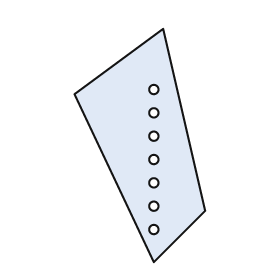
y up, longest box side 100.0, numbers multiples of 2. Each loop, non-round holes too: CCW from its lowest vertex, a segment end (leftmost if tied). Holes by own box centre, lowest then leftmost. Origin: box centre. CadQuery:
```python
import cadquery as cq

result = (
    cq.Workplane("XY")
    .moveTo(6.0, -50.0)
    .lineTo(28.0, -28.0)
    .lineTo(10.0, 50.0)
    .lineTo(-28.0, 22.0)
    .close()
    .moveTo(6.0, -36.0)
    .circle(2.0)
    .moveTo(6.0, -26.0)
    .circle(2.0)
    .moveTo(6.0, -16.0)
    .circle(2.0)
    .moveTo(6.0, -6.0)
    .circle(2.0)
    .moveTo(6.0, 4.0)
    .circle(2.0)
    .moveTo(6.0, 14.0)
    .circle(2.0)
    .moveTo(6.0, 24.0)
    .circle(2.0)
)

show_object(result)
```